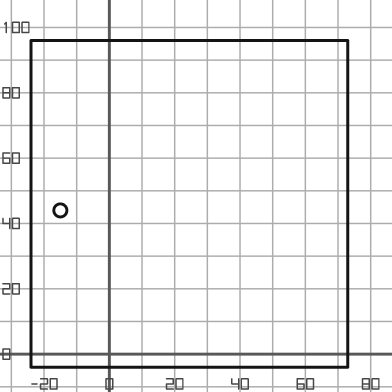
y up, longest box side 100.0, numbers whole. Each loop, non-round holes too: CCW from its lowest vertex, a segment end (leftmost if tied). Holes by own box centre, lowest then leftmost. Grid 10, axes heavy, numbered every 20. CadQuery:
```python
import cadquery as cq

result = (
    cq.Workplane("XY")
    .moveTo(-24.0, -4.0)
    .lineTo(73.0, -4.0)
    .lineTo(73.0, 96.0)
    .lineTo(-24.0, 96.0)
    .close()
    .moveTo(-15.0, 44.0)
    .circle(2.0)
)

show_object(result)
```